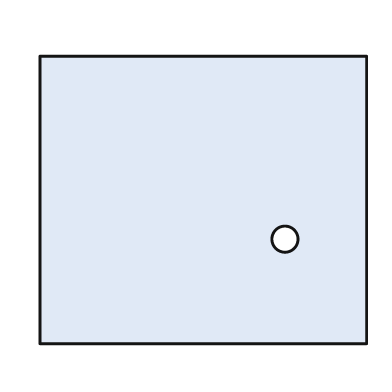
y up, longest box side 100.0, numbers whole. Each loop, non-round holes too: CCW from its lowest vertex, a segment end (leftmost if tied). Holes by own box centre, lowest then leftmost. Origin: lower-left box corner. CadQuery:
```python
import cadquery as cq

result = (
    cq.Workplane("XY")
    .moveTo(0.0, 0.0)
    .lineTo(100.0, 0.0)
    .lineTo(100.0, 88.0)
    .lineTo(0.0, 88.0)
    .close()
    .moveTo(75.0, 32.0)
    .circle(4.0)
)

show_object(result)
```